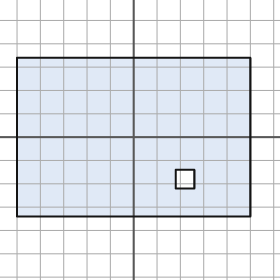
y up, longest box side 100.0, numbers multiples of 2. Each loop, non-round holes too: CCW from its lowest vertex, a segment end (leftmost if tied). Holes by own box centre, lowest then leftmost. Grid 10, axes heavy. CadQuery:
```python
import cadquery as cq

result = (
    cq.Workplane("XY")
    .moveTo(-50.0, -34.0)
    .lineTo(50.0, -34.0)
    .lineTo(50.0, 34.0)
    .lineTo(-50.0, 34.0)
    .close()
    .moveTo(18.0, -22.0)
    .lineTo(26.0, -22.0)
    .lineTo(26.0, -14.0)
    .lineTo(18.0, -14.0)
    .close()
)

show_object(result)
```